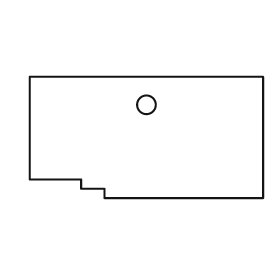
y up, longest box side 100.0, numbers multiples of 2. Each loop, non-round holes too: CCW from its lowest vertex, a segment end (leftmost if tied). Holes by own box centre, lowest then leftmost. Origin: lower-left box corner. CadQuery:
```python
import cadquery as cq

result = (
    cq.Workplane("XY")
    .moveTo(32.0, 0.0)
    .lineTo(100.0, 0.0)
    .lineTo(100.0, 52.0)
    .lineTo(0.0, 52.0)
    .lineTo(0.0, 8.0)
    .lineTo(22.0, 8.0)
    .lineTo(22.0, 4.0)
    .lineTo(32.0, 4.0)
    .close()
    .moveTo(50.0, 40.0)
    .circle(4.0)
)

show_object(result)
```